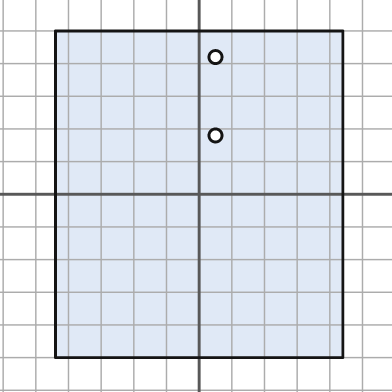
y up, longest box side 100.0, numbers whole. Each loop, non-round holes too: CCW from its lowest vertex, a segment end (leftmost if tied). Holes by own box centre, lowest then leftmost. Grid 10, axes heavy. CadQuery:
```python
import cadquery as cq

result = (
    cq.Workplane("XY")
    .moveTo(-44.0, -50.0)
    .lineTo(44.0, -50.0)
    .lineTo(44.0, 50.0)
    .lineTo(-44.0, 50.0)
    .close()
    .moveTo(5.0, 18.0)
    .circle(2.0)
    .moveTo(5.0, 42.0)
    .circle(2.0)
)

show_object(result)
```